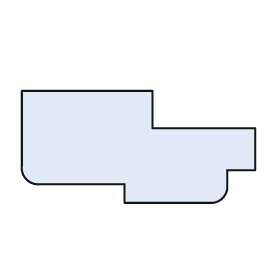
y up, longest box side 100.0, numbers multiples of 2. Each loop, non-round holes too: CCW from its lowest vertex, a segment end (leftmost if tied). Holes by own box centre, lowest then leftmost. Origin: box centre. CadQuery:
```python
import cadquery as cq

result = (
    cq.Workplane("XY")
    .moveTo(-6.0, -24.0)
    .lineTo(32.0, -24.0)
    .threePointArc((36.0, -22.0), (38.0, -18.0))
    .lineTo(38.0, -10.0)
    .lineTo(50.0, -10.0)
    .lineTo(50.0, 8.0)
    .lineTo(6.0, 8.0)
    .lineTo(6.0, 24.0)
    .lineTo(-50.0, 24.0)
    .lineTo(-50.0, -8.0)
    .threePointArc((-48.0, -14.0), (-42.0, -16.0))
    .lineTo(-6.0, -16.0)
    .close()
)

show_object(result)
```